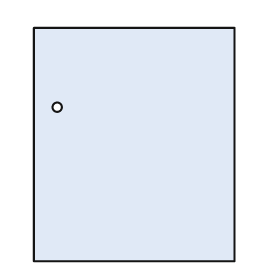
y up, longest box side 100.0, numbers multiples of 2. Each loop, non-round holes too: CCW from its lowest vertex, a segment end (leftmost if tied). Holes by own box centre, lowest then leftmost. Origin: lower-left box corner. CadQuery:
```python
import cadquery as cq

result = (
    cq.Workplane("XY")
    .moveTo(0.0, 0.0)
    .lineTo(86.0, 0.0)
    .lineTo(86.0, 100.0)
    .lineTo(0.0, 100.0)
    .close()
    .moveTo(10.0, 66.0)
    .circle(2.0)
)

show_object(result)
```